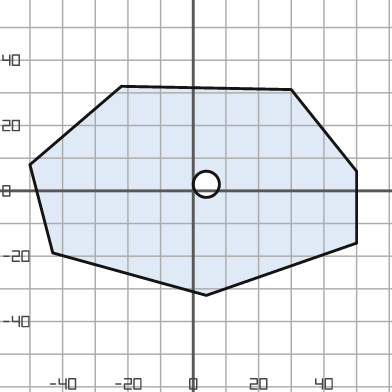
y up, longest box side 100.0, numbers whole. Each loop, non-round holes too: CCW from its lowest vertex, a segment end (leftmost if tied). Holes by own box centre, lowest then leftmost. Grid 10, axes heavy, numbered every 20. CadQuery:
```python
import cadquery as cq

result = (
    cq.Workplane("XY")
    .moveTo(4.0, -32.0)
    .lineTo(50.0, -16.0)
    .lineTo(50.0, 6.0)
    .lineTo(30.0, 31.0)
    .lineTo(-22.0, 32.0)
    .lineTo(-50.0, 8.0)
    .lineTo(-43.0, -19.0)
    .close()
    .moveTo(4.0, 2.0)
    .circle(4.0)
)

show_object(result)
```